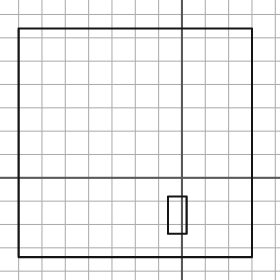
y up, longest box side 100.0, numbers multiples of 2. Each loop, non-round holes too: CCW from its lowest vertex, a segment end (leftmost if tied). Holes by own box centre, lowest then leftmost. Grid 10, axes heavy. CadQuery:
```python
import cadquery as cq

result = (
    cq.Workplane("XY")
    .moveTo(-70.0, -34.0)
    .lineTo(30.0, -34.0)
    .lineTo(30.0, 64.0)
    .lineTo(-70.0, 64.0)
    .close()
    .moveTo(-6.0, -24.0)
    .lineTo(2.0, -24.0)
    .lineTo(2.0, -8.0)
    .lineTo(-6.0, -8.0)
    .close()
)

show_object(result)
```